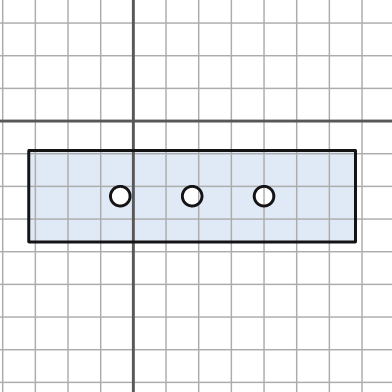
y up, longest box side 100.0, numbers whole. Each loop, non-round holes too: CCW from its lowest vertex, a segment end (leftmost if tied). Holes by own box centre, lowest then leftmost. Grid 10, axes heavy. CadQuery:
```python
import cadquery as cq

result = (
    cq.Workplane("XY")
    .moveTo(-32.0, -37.0)
    .lineTo(68.0, -37.0)
    .lineTo(68.0, -9.0)
    .lineTo(-32.0, -9.0)
    .close()
    .moveTo(-4.0, -23.0)
    .circle(3.0)
    .moveTo(18.0, -23.0)
    .circle(3.0)
    .moveTo(40.0, -23.0)
    .circle(3.0)
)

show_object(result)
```